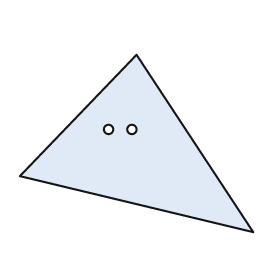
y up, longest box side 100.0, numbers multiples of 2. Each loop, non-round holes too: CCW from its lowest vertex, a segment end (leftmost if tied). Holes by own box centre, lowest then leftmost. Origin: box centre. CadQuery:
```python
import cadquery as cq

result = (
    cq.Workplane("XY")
    .moveTo(50.0, -38.0)
    .lineTo(0.0, 38.0)
    .lineTo(-50.0, -14.0)
    .close()
    .moveTo(-12.0, 6.0)
    .circle(2.0)
    .moveTo(-2.0, 6.0)
    .circle(2.0)
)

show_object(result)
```